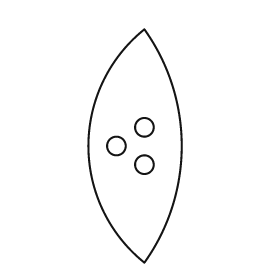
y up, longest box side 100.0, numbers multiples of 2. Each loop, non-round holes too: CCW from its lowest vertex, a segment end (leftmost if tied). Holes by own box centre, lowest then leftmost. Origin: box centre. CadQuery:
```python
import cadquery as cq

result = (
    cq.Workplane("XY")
    .moveTo(4.0, -50.0)
    .threePointArc((20.0, 0.0), (4.0, 50.0))
    .threePointArc((-20.0, 0.0), (4.0, -50.0))
    .close()
    .moveTo(4.0, -8.0)
    .circle(4.0)
    .moveTo(-8.0, 0.0)
    .circle(4.0)
    .moveTo(4.0, 8.0)
    .circle(4.0)
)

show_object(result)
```